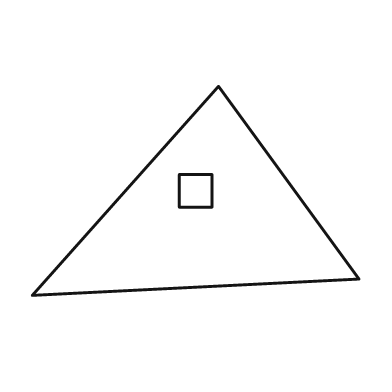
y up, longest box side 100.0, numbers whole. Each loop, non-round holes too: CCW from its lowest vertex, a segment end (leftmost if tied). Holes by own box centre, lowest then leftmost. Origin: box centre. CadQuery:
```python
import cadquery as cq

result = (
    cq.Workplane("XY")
    .moveTo(-50.0, -32.0)
    .lineTo(50.0, -27.0)
    .lineTo(7.0, 32.0)
    .close()
    .moveTo(-5.0, -5.0)
    .lineTo(5.0, -5.0)
    .lineTo(5.0, 5.0)
    .lineTo(-5.0, 5.0)
    .close()
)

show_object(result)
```